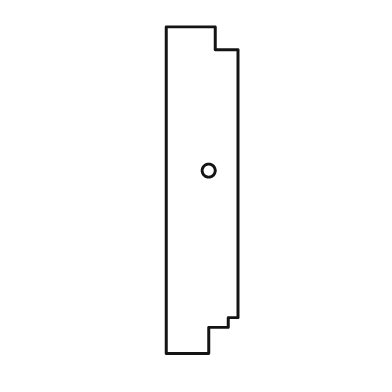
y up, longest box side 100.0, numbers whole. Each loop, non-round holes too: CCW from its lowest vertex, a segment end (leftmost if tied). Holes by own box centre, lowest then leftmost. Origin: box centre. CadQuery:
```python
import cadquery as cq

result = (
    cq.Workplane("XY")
    .moveTo(-11.0, -50.0)
    .lineTo(2.0, -50.0)
    .lineTo(2.0, -42.0)
    .lineTo(8.0, -42.0)
    .lineTo(8.0, -39.0)
    .lineTo(11.0, -39.0)
    .lineTo(11.0, 43.0)
    .lineTo(4.0, 43.0)
    .lineTo(4.0, 50.0)
    .lineTo(-11.0, 50.0)
    .close()
    .moveTo(2.0, 6.0)
    .circle(2.0)
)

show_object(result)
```